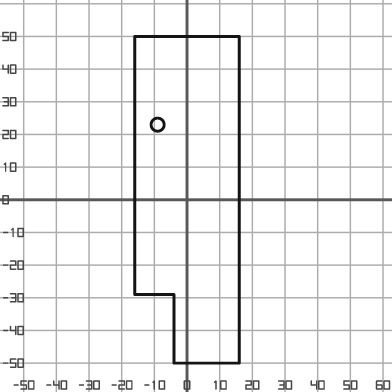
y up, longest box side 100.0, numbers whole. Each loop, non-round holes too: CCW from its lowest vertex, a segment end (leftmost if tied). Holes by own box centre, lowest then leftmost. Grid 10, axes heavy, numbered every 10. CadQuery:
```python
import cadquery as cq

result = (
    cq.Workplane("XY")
    .moveTo(-4.0, -50.0)
    .lineTo(16.0, -50.0)
    .lineTo(16.0, 50.0)
    .lineTo(-16.0, 50.0)
    .lineTo(-16.0, -29.0)
    .lineTo(-4.0, -29.0)
    .close()
    .moveTo(-9.0, 23.0)
    .circle(2.0)
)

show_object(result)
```